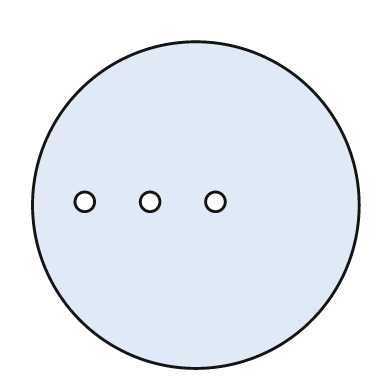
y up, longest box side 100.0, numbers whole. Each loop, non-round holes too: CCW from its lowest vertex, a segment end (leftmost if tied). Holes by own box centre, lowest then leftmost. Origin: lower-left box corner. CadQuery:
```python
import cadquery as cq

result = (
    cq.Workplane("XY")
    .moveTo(50.0, 50.0)
    .circle(50.0)
    .moveTo(16.0, 51.0)
    .circle(3.0)
    .moveTo(36.0, 51.0)
    .circle(3.0)
    .moveTo(56.0, 51.0)
    .circle(3.0)
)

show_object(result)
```